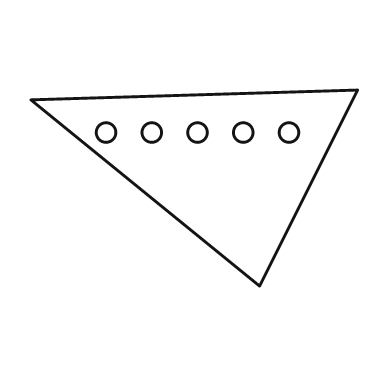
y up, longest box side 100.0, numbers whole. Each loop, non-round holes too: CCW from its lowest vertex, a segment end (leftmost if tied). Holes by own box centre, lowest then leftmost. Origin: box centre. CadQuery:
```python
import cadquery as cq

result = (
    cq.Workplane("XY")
    .moveTo(20.0, -30.0)
    .lineTo(50.0, 30.0)
    .lineTo(-50.0, 27.0)
    .close()
    .moveTo(-27.0, 17.0)
    .circle(3.0)
    .moveTo(-13.0, 17.0)
    .circle(3.0)
    .moveTo(1.0, 17.0)
    .circle(3.0)
    .moveTo(15.0, 17.0)
    .circle(3.0)
    .moveTo(29.0, 17.0)
    .circle(3.0)
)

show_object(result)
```